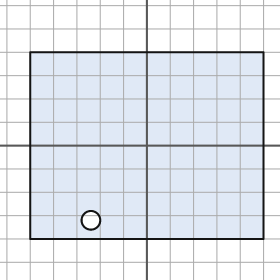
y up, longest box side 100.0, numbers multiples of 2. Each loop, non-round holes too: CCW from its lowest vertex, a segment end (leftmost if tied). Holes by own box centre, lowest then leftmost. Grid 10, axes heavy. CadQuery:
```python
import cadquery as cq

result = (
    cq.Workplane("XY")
    .moveTo(-50.0, -40.0)
    .lineTo(50.0, -40.0)
    .lineTo(50.0, 40.0)
    .lineTo(-50.0, 40.0)
    .close()
    .moveTo(-24.0, -32.0)
    .circle(4.0)
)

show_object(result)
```